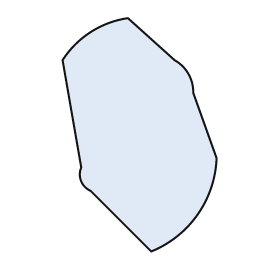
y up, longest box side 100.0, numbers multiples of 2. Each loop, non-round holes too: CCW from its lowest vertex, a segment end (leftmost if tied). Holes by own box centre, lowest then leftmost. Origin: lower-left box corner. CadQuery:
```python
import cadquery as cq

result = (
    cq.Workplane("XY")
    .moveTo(38.0, 0.0)
    .threePointArc((58.0, 16.0), (66.0, 40.0))
    .lineTo(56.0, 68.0)
    .threePointArc((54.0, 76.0), (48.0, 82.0))
    .lineTo(28.0, 100.0)
    .threePointArc((12.0, 94.0), (0.0, 82.0))
    .lineTo(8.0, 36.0)
    .threePointArc((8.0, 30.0), (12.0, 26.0))
    .close()
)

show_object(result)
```